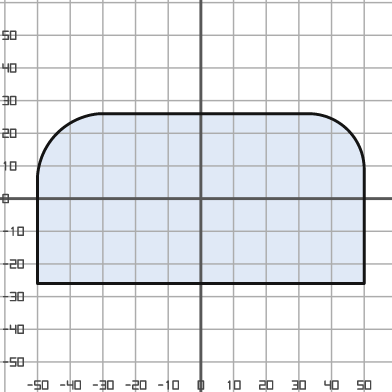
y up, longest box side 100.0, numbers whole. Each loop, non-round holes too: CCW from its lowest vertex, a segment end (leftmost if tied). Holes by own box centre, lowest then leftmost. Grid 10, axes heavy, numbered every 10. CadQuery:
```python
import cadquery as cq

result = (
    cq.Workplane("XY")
    .moveTo(-50.0, -26.0)
    .lineTo(50.0, -26.0)
    .lineTo(50.0, 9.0)
    .threePointArc((45.0, 21.0), (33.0, 26.0))
    .lineTo(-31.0, 26.0)
    .threePointArc((-44.0, 20.0), (-50.0, 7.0))
    .close()
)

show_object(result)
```